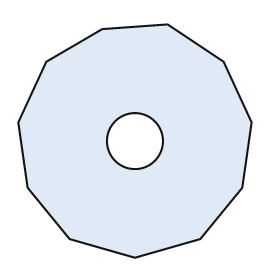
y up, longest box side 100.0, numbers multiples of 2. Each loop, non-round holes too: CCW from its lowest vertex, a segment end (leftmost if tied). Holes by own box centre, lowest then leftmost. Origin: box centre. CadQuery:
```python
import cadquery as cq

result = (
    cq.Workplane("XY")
    .moveTo(0.0, -50.0)
    .lineTo(28.0, -42.0)
    .lineTo(46.0, -20.0)
    .lineTo(50.0, 8.0)
    .lineTo(38.0, 34.0)
    .lineTo(14.0, 50.0)
    .lineTo(-14.0, 48.0)
    .lineTo(-38.0, 34.0)
    .lineTo(-50.0, 8.0)
    .lineTo(-46.0, -20.0)
    .lineTo(-28.0, -42.0)
    .close()
    .moveTo(0.0, 0.0)
    .circle(12.0)
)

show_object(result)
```